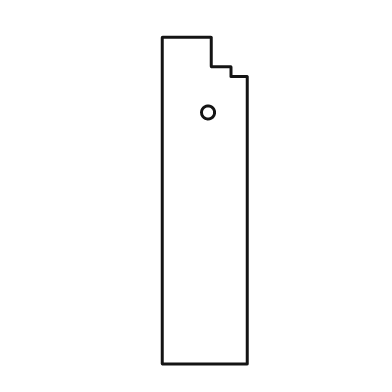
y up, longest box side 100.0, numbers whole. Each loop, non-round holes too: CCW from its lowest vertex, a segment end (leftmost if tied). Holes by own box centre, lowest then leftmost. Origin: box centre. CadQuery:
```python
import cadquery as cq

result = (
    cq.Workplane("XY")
    .moveTo(-13.0, -50.0)
    .lineTo(13.0, -50.0)
    .lineTo(13.0, 38.0)
    .lineTo(8.0, 38.0)
    .lineTo(8.0, 41.0)
    .lineTo(2.0, 41.0)
    .lineTo(2.0, 50.0)
    .lineTo(-13.0, 50.0)
    .close()
    .moveTo(1.0, 27.0)
    .circle(2.0)
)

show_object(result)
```